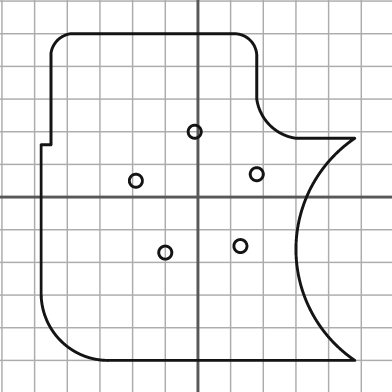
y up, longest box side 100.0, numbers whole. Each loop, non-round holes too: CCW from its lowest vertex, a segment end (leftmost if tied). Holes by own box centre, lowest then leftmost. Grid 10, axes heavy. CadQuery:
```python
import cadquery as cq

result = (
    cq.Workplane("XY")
    .moveTo(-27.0, -50.0)
    .lineTo(48.0, -50.0)
    .threePointArc((30.0, -16.0), (48.0, 18.0))
    .lineTo(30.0, 18.0)
    .threePointArc((22.0, 22.0), (18.0, 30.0))
    .lineTo(18.0, 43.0)
    .threePointArc((16.0, 48.0), (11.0, 50.0))
    .lineTo(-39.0, 50.0)
    .threePointArc((-43.0, 48.0), (-45.0, 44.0))
    .lineTo(-45.0, 16.0)
    .lineTo(-48.0, 16.0)
    .lineTo(-48.0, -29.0)
    .threePointArc((-42.0, -44.0), (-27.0, -50.0))
    .close()
    .moveTo(-10.0, -17.0)
    .circle(2.0)
    .moveTo(13.0, -15.0)
    .circle(2.0)
    .moveTo(-19.0, 5.0)
    .circle(2.0)
    .moveTo(18.0, 7.0)
    .circle(2.0)
    .moveTo(-1.0, 20.0)
    .circle(2.0)
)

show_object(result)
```